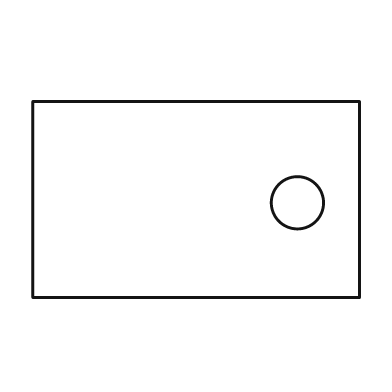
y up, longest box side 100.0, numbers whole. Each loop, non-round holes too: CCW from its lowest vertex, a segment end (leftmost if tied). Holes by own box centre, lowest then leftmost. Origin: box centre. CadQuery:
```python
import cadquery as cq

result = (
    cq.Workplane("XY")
    .moveTo(-50.0, -30.0)
    .lineTo(50.0, -30.0)
    .lineTo(50.0, 30.0)
    .lineTo(-50.0, 30.0)
    .close()
    .moveTo(31.0, -1.0)
    .circle(8.0)
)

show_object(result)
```